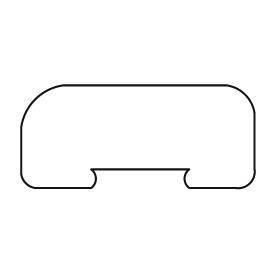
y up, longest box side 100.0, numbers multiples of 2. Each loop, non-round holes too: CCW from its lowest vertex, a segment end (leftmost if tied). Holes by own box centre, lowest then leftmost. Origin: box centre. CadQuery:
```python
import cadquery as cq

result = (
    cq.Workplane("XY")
    .moveTo(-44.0, -22.0)
    .lineTo(-20.0, -22.0)
    .threePointArc((-18.0, -18.0), (-20.0, -14.0))
    .lineTo(22.0, -14.0)
    .threePointArc((20.0, -18.0), (22.0, -22.0))
    .lineTo(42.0, -22.0)
    .threePointArc((48.0, -20.0), (50.0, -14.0))
    .lineTo(50.0, 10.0)
    .threePointArc((46.0, 18.0), (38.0, 22.0))
    .lineTo(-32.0, 22.0)
    .threePointArc((-44.0, 16.0), (-50.0, 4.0))
    .lineTo(-50.0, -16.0)
    .threePointArc((-48.0, -20.0), (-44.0, -22.0))
    .close()
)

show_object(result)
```